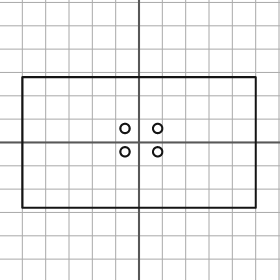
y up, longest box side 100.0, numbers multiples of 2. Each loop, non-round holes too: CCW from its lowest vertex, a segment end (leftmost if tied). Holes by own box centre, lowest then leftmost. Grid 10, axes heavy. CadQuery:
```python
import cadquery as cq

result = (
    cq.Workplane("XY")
    .moveTo(-50.0, -28.0)
    .lineTo(50.0, -28.0)
    .lineTo(50.0, 28.0)
    .lineTo(-50.0, 28.0)
    .close()
    .moveTo(-6.0, -4.0)
    .circle(2.0)
    .moveTo(8.0, -4.0)
    .circle(2.0)
    .moveTo(-6.0, 6.0)
    .circle(2.0)
    .moveTo(8.0, 6.0)
    .circle(2.0)
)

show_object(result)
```